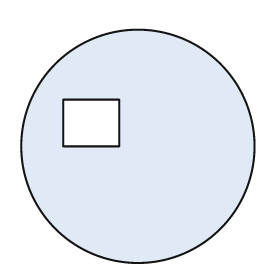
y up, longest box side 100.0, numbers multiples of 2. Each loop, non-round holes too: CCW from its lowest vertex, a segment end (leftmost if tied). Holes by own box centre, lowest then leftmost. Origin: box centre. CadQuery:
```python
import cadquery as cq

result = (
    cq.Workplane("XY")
    .moveTo(0.0, 0.0)
    .circle(50.0)
    .moveTo(-32.0, 0.0)
    .lineTo(-8.0, 0.0)
    .lineTo(-8.0, 20.0)
    .lineTo(-32.0, 20.0)
    .close()
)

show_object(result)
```